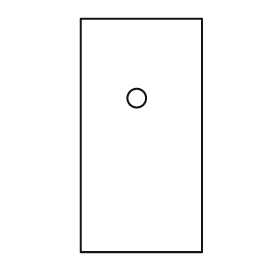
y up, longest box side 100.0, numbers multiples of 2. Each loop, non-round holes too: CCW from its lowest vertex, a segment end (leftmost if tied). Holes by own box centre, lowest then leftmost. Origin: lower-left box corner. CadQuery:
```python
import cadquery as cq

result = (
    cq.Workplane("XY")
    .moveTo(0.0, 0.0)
    .lineTo(52.0, 0.0)
    .lineTo(52.0, 100.0)
    .lineTo(0.0, 100.0)
    .close()
    .moveTo(24.0, 66.0)
    .circle(4.0)
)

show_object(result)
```